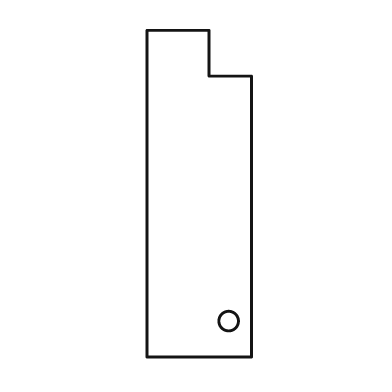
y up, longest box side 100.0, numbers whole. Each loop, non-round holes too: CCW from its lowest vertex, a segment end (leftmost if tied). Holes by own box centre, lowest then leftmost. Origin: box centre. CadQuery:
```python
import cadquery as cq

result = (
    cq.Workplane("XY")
    .moveTo(-16.0, -50.0)
    .lineTo(16.0, -50.0)
    .lineTo(16.0, 36.0)
    .lineTo(3.0, 36.0)
    .lineTo(3.0, 50.0)
    .lineTo(-16.0, 50.0)
    .close()
    .moveTo(9.0, -39.0)
    .circle(3.0)
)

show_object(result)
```